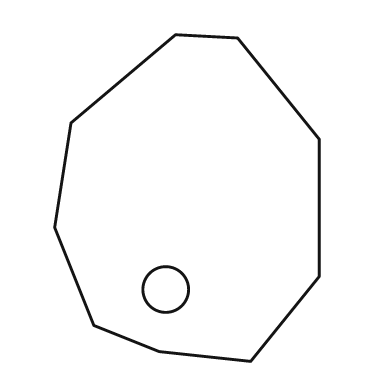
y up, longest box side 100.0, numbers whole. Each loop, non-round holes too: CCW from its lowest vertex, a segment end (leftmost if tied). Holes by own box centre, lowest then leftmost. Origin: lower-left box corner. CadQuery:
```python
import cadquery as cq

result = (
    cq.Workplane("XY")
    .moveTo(60.0, 0.0)
    .lineTo(81.0, 26.0)
    .lineTo(81.0, 68.0)
    .lineTo(56.0, 99.0)
    .lineTo(37.0, 100.0)
    .lineTo(5.0, 73.0)
    .lineTo(0.0, 41.0)
    .lineTo(12.0, 11.0)
    .lineTo(32.0, 3.0)
    .close()
    .moveTo(34.0, 22.0)
    .circle(7.0)
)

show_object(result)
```